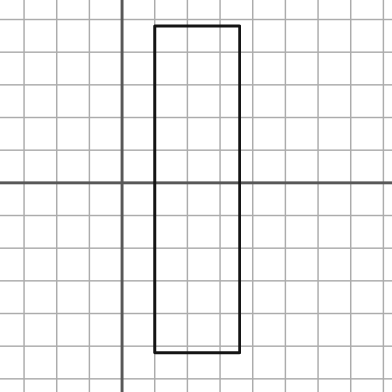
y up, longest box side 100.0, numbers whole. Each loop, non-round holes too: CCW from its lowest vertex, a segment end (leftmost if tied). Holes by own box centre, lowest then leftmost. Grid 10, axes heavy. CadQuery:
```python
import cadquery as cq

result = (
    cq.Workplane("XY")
    .moveTo(10.0, -52.0)
    .lineTo(36.0, -52.0)
    .lineTo(36.0, 48.0)
    .lineTo(10.0, 48.0)
    .close()
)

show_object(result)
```